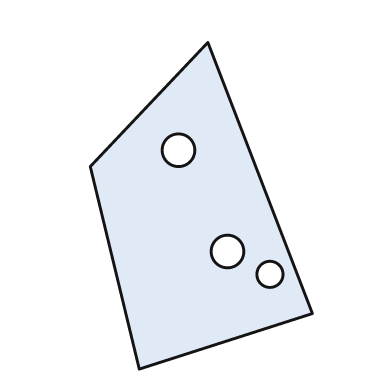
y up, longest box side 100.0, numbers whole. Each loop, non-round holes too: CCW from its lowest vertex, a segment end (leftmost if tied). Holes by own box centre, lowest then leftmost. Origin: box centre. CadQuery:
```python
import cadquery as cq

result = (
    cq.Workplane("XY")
    .moveTo(-19.0, -50.0)
    .lineTo(34.0, -33.0)
    .lineTo(2.0, 50.0)
    .lineTo(-34.0, 12.0)
    .close()
    .moveTo(21.0, -21.0)
    .circle(4.0)
    .moveTo(8.0, -14.0)
    .circle(5.0)
    .moveTo(-7.0, 17.0)
    .circle(5.0)
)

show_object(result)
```